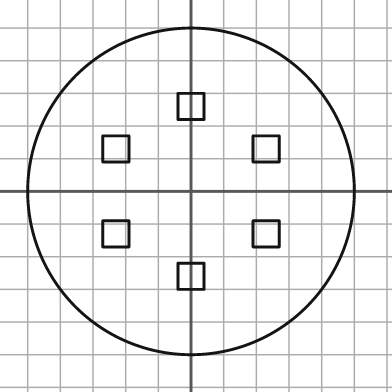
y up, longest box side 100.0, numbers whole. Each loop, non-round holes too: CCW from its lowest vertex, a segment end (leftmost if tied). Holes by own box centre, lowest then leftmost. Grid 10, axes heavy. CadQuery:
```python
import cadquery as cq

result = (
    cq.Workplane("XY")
    .moveTo(0.0, 0.0)
    .circle(50.0)
    .moveTo(-4.0, -30.0)
    .lineTo(4.0, -30.0)
    .lineTo(4.0, -22.0)
    .lineTo(-4.0, -22.0)
    .close()
    .moveTo(-27.0, -17.0)
    .lineTo(-19.0, -17.0)
    .lineTo(-19.0, -9.0)
    .lineTo(-27.0, -9.0)
    .close()
    .moveTo(19.0, -17.0)
    .lineTo(27.0, -17.0)
    .lineTo(27.0, -9.0)
    .lineTo(19.0, -9.0)
    .close()
    .moveTo(-27.0, 9.0)
    .lineTo(-19.0, 9.0)
    .lineTo(-19.0, 17.0)
    .lineTo(-27.0, 17.0)
    .close()
    .moveTo(19.0, 9.0)
    .lineTo(27.0, 9.0)
    .lineTo(27.0, 17.0)
    .lineTo(19.0, 17.0)
    .close()
    .moveTo(-4.0, 22.0)
    .lineTo(4.0, 22.0)
    .lineTo(4.0, 30.0)
    .lineTo(-4.0, 30.0)
    .close()
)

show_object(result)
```